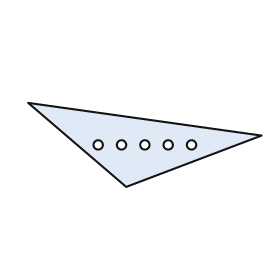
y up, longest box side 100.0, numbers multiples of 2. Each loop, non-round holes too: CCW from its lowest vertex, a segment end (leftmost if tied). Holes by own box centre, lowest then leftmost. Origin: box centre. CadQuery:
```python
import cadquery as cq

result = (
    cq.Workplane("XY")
    .moveTo(-8.0, -18.0)
    .lineTo(50.0, 4.0)
    .lineTo(-50.0, 18.0)
    .close()
    .moveTo(-20.0, 0.0)
    .circle(2.0)
    .moveTo(-10.0, 0.0)
    .circle(2.0)
    .moveTo(0.0, 0.0)
    .circle(2.0)
    .moveTo(10.0, 0.0)
    .circle(2.0)
    .moveTo(20.0, 0.0)
    .circle(2.0)
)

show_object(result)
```